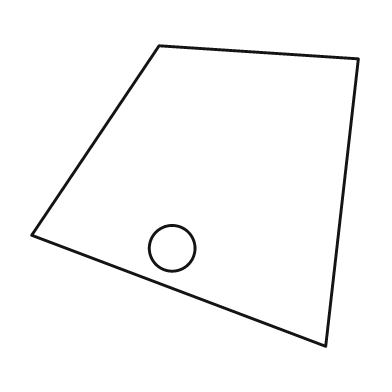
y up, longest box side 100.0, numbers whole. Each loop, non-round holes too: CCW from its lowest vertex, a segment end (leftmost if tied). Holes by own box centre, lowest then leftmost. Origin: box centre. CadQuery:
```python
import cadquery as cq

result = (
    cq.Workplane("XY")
    .moveTo(40.0, -46.0)
    .lineTo(50.0, 42.0)
    .lineTo(-11.0, 46.0)
    .lineTo(-50.0, -12.0)
    .close()
    .moveTo(-7.0, -16.0)
    .circle(7.0)
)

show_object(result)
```